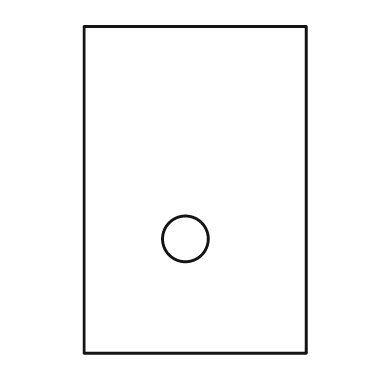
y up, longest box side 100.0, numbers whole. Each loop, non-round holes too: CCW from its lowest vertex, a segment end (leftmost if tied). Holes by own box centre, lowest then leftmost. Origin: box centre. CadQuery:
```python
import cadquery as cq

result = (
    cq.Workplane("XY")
    .moveTo(-34.0, -50.0)
    .lineTo(34.0, -50.0)
    .lineTo(34.0, 50.0)
    .lineTo(-34.0, 50.0)
    .close()
    .moveTo(-3.0, -15.0)
    .circle(7.0)
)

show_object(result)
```